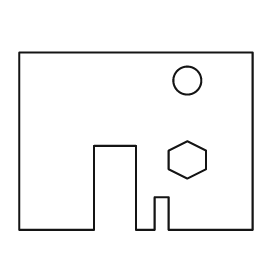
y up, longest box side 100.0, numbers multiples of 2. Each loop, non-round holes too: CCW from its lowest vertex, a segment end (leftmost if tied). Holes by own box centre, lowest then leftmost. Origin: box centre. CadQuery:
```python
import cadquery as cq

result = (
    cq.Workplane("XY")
    .moveTo(-50.0, -38.0)
    .lineTo(-18.0, -38.0)
    .lineTo(-18.0, -2.0)
    .lineTo(0.0, -2.0)
    .lineTo(0.0, -38.0)
    .lineTo(8.0, -38.0)
    .lineTo(8.0, -24.0)
    .lineTo(14.0, -24.0)
    .lineTo(14.0, -38.0)
    .lineTo(50.0, -38.0)
    .lineTo(50.0, 38.0)
    .lineTo(-50.0, 38.0)
    .close()
    .moveTo(22.0, -16.0)
    .lineTo(30.0, -12.0)
    .lineTo(30.0, -4.0)
    .lineTo(22.0, 0.0)
    .lineTo(14.0, -4.0)
    .lineTo(14.0, -12.0)
    .close()
    .moveTo(22.0, 26.0)
    .circle(6.0)
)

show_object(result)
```